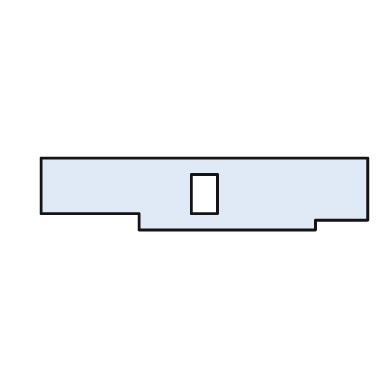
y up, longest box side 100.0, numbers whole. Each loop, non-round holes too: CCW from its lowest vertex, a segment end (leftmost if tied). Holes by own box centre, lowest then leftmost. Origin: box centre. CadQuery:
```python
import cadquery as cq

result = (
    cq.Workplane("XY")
    .moveTo(-20.0, -11.0)
    .lineTo(34.0, -11.0)
    .lineTo(34.0, -8.0)
    .lineTo(50.0, -8.0)
    .lineTo(50.0, 11.0)
    .lineTo(-50.0, 11.0)
    .lineTo(-50.0, -6.0)
    .lineTo(-20.0, -6.0)
    .close()
    .moveTo(-4.0, -6.0)
    .lineTo(4.0, -6.0)
    .lineTo(4.0, 6.0)
    .lineTo(-4.0, 6.0)
    .close()
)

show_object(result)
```